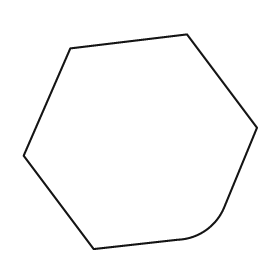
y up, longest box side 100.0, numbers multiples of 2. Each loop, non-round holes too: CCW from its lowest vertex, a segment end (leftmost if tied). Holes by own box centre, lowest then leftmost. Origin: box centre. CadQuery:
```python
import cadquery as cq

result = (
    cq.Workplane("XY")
    .moveTo(-20.0, -46.0)
    .lineTo(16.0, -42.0)
    .threePointArc((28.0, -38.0), (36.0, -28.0))
    .lineTo(50.0, 6.0)
    .lineTo(20.0, 46.0)
    .lineTo(-30.0, 40.0)
    .lineTo(-50.0, -6.0)
    .close()
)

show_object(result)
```